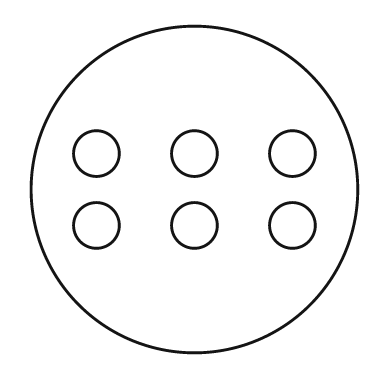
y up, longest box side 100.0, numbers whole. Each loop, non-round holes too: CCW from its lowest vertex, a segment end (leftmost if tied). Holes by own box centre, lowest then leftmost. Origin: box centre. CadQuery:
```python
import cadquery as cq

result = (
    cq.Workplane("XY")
    .moveTo(0.0, 0.0)
    .circle(50.0)
    .moveTo(-30.0, -11.0)
    .circle(7.0)
    .moveTo(0.0, -11.0)
    .circle(7.0)
    .moveTo(30.0, -11.0)
    .circle(7.0)
    .moveTo(-30.0, 11.0)
    .circle(7.0)
    .moveTo(0.0, 11.0)
    .circle(7.0)
    .moveTo(30.0, 11.0)
    .circle(7.0)
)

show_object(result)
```